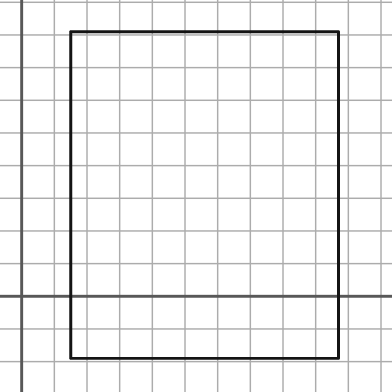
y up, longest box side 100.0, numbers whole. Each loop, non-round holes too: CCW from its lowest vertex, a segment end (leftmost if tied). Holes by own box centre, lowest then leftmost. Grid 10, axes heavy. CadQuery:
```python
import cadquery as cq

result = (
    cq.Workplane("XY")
    .moveTo(15.0, -19.0)
    .lineTo(97.0, -19.0)
    .lineTo(97.0, 81.0)
    .lineTo(15.0, 81.0)
    .close()
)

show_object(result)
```